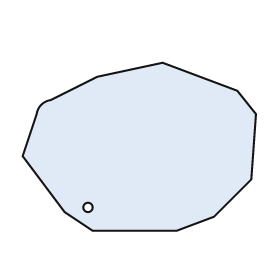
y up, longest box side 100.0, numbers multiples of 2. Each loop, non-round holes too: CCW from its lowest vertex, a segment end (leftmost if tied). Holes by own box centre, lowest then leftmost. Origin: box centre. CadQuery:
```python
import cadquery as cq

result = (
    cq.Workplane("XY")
    .moveTo(-20.0, -36.0)
    .lineTo(16.0, -36.0)
    .lineTo(32.0, -30.0)
    .lineTo(48.0, -14.0)
    .lineTo(50.0, 14.0)
    .lineTo(42.0, 24.0)
    .lineTo(10.0, 36.0)
    .lineTo(-18.0, 30.0)
    .lineTo(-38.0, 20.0)
    .threePointArc((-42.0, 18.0), (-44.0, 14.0))
    .lineTo(-50.0, -4.0)
    .lineTo(-32.0, -28.0)
    .close()
    .moveTo(-22.0, -26.0)
    .circle(2.0)
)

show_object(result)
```